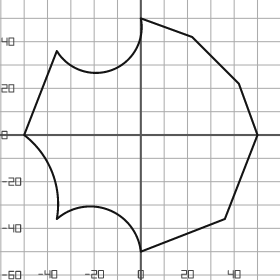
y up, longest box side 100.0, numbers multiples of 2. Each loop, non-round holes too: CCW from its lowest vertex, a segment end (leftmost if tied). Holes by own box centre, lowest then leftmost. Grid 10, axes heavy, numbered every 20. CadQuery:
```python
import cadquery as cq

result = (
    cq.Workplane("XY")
    .moveTo(0.0, -50.0)
    .lineTo(36.0, -36.0)
    .lineTo(50.0, 0.0)
    .lineTo(42.0, 22.0)
    .lineTo(22.0, 42.0)
    .lineTo(0.0, 50.0)
    .threePointArc((-12.0, 28.0), (-36.0, 36.0))
    .lineTo(-50.0, 0.0)
    .threePointArc((-38.0, -16.0), (-36.0, -36.0))
    .threePointArc((-14.0, -32.0), (0.0, -50.0))
    .close()
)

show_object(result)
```